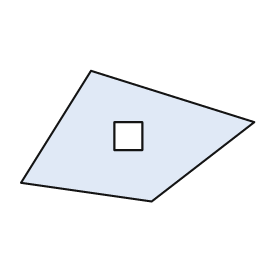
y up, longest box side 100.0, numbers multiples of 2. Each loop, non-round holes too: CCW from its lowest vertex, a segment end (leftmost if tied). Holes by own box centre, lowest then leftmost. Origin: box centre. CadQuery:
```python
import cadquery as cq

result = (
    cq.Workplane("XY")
    .moveTo(6.0, -28.0)
    .lineTo(50.0, 6.0)
    .lineTo(-20.0, 28.0)
    .lineTo(-50.0, -20.0)
    .close()
    .moveTo(-10.0, -6.0)
    .lineTo(2.0, -6.0)
    .lineTo(2.0, 6.0)
    .lineTo(-10.0, 6.0)
    .close()
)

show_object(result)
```